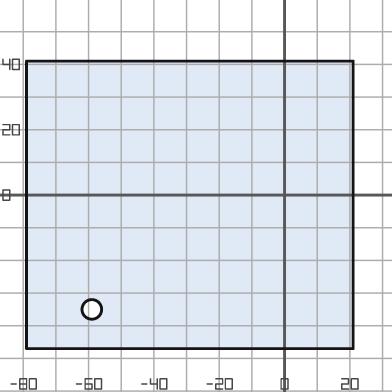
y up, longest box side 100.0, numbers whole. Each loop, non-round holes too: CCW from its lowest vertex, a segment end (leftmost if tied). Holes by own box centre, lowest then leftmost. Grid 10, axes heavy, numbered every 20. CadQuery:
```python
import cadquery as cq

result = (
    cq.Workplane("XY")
    .moveTo(-79.0, -47.0)
    .lineTo(21.0, -47.0)
    .lineTo(21.0, 41.0)
    .lineTo(-79.0, 41.0)
    .close()
    .moveTo(-59.0, -35.0)
    .circle(3.0)
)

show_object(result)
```